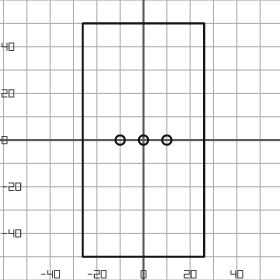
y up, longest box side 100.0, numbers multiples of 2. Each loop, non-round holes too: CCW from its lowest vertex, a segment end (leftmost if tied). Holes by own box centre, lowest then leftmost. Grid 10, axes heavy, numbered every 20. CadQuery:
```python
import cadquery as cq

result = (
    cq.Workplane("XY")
    .moveTo(-26.0, -50.0)
    .lineTo(26.0, -50.0)
    .lineTo(26.0, 50.0)
    .lineTo(-26.0, 50.0)
    .close()
    .moveTo(-10.0, 0.0)
    .circle(2.0)
    .moveTo(0.0, 0.0)
    .circle(2.0)
    .moveTo(10.0, 0.0)
    .circle(2.0)
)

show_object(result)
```